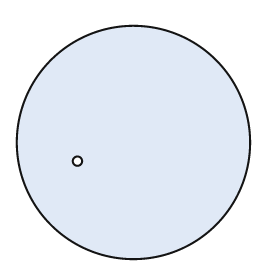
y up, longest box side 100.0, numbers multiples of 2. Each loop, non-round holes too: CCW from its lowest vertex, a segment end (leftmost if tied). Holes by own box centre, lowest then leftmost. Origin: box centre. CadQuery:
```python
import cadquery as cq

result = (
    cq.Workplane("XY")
    .moveTo(0.0, 0.0)
    .circle(50.0)
    .moveTo(-24.0, -8.0)
    .circle(2.0)
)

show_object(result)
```